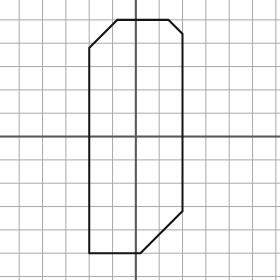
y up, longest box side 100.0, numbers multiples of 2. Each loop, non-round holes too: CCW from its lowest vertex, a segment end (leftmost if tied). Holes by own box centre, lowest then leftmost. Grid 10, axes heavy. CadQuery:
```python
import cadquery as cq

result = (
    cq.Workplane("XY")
    .moveTo(-20.0, -50.0)
    .lineTo(2.0, -50.0)
    .lineTo(20.0, -32.0)
    .lineTo(20.0, 44.0)
    .lineTo(14.0, 50.0)
    .lineTo(-8.0, 50.0)
    .lineTo(-20.0, 38.0)
    .close()
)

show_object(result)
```